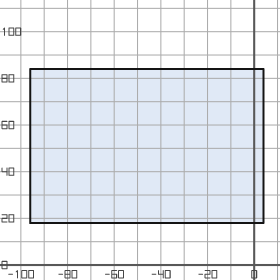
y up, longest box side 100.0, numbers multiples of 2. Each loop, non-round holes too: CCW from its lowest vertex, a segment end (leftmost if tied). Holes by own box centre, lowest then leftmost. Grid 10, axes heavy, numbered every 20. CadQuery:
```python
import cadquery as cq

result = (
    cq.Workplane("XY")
    .moveTo(-96.0, 18.0)
    .lineTo(4.0, 18.0)
    .lineTo(4.0, 84.0)
    .lineTo(-96.0, 84.0)
    .close()
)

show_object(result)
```